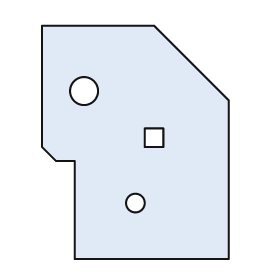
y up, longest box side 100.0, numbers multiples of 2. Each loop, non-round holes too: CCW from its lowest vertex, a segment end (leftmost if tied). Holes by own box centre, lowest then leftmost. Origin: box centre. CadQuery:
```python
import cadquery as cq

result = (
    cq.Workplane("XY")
    .moveTo(-26.0, -50.0)
    .lineTo(40.0, -50.0)
    .lineTo(40.0, 18.0)
    .lineTo(8.0, 50.0)
    .lineTo(-40.0, 50.0)
    .lineTo(-40.0, -2.0)
    .lineTo(-34.0, -8.0)
    .lineTo(-26.0, -8.0)
    .close()
    .moveTo(0.0, -26.0)
    .circle(4.0)
    .moveTo(4.0, -2.0)
    .lineTo(12.0, -2.0)
    .lineTo(12.0, 6.0)
    .lineTo(4.0, 6.0)
    .close()
    .moveTo(-22.0, 22.0)
    .circle(6.0)
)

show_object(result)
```